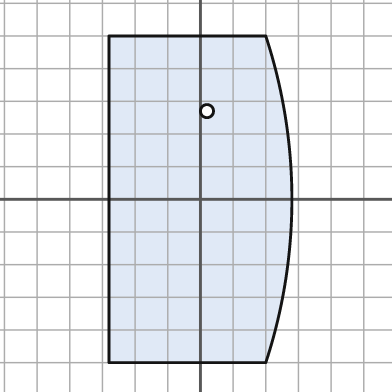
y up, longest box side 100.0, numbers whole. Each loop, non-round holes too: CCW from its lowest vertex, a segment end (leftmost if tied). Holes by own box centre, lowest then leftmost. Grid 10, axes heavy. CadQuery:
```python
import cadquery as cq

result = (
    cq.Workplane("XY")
    .moveTo(-28.0, -50.0)
    .lineTo(20.0, -50.0)
    .threePointArc((28.0, 0.0), (20.0, 50.0))
    .lineTo(-28.0, 50.0)
    .close()
    .moveTo(2.0, 27.0)
    .circle(2.0)
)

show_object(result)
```